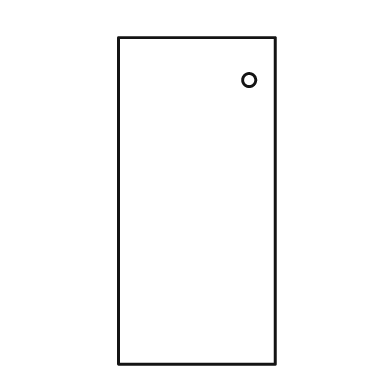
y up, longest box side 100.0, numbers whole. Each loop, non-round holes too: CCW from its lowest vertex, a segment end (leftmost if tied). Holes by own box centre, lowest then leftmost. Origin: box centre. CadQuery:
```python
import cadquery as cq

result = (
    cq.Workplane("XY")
    .moveTo(-24.0, -50.0)
    .lineTo(24.0, -50.0)
    .lineTo(24.0, 50.0)
    .lineTo(-24.0, 50.0)
    .close()
    .moveTo(16.0, 37.0)
    .circle(2.0)
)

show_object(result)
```